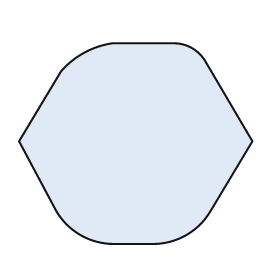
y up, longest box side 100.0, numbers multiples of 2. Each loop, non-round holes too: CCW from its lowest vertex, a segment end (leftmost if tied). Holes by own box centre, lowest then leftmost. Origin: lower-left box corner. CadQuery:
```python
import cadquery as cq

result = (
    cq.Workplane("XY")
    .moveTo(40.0, 0.0)
    .lineTo(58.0, 0.0)
    .threePointArc((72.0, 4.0), (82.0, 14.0))
    .lineTo(100.0, 44.0)
    .lineTo(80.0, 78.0)
    .threePointArc((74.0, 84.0), (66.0, 86.0))
    .lineTo(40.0, 86.0)
    .threePointArc((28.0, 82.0), (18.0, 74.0))
    .lineTo(0.0, 44.0)
    .lineTo(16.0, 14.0)
    .threePointArc((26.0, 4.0), (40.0, 0.0))
    .close()
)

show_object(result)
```